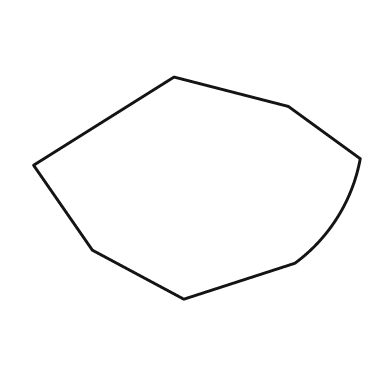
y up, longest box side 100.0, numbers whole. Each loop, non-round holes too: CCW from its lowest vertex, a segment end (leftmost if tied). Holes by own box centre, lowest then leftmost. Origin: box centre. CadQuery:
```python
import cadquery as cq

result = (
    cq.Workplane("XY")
    .moveTo(-4.0, -34.0)
    .lineTo(30.0, -23.0)
    .threePointArc((43.0, -9.0), (50.0, 9.0))
    .lineTo(28.0, 25.0)
    .lineTo(-7.0, 34.0)
    .lineTo(-50.0, 7.0)
    .lineTo(-32.0, -19.0)
    .close()
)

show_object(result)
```